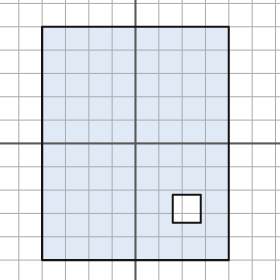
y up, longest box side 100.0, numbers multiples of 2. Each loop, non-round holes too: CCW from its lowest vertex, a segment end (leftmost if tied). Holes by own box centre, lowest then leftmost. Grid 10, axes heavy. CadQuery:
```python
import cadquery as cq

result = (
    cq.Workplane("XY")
    .moveTo(-40.0, -50.0)
    .lineTo(40.0, -50.0)
    .lineTo(40.0, 50.0)
    .lineTo(-40.0, 50.0)
    .close()
    .moveTo(16.0, -34.0)
    .lineTo(28.0, -34.0)
    .lineTo(28.0, -22.0)
    .lineTo(16.0, -22.0)
    .close()
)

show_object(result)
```